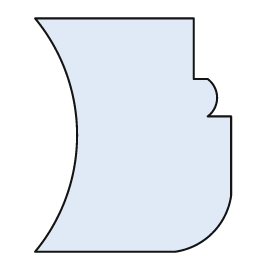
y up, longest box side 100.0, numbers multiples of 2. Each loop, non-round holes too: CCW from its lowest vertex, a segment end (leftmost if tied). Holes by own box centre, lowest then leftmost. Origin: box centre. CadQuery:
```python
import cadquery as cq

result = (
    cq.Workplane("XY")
    .moveTo(-42.0, -50.0)
    .lineTo(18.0, -50.0)
    .threePointArc((34.0, -42.0), (42.0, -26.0))
    .lineTo(42.0, 8.0)
    .lineTo(32.0, 8.0)
    .threePointArc((36.0, 16.0), (32.0, 24.0))
    .lineTo(26.0, 24.0)
    .lineTo(26.0, 50.0)
    .lineTo(-42.0, 50.0)
    .threePointArc((-24.0, 0.0), (-42.0, -50.0))
    .close()
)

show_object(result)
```